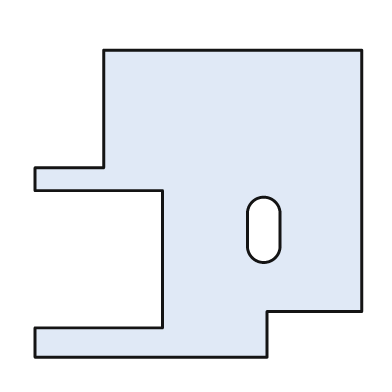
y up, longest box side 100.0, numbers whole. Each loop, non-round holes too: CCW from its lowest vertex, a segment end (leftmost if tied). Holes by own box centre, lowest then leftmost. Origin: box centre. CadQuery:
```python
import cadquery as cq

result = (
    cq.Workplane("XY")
    .moveTo(-50.0, -47.0)
    .lineTo(21.0, -47.0)
    .lineTo(21.0, -33.0)
    .lineTo(50.0, -33.0)
    .lineTo(50.0, 47.0)
    .lineTo(-29.0, 47.0)
    .lineTo(-29.0, 11.0)
    .lineTo(-50.0, 11.0)
    .lineTo(-50.0, 4.0)
    .lineTo(-11.0, 4.0)
    .lineTo(-11.0, -38.0)
    .lineTo(-50.0, -38.0)
    .close()
    .moveTo(15.0, -13.0)
    .threePointArc((20.0, -18.0), (25.0, -13.0))
    .lineTo(25.0, -3.0)
    .threePointArc((20.0, 2.0), (15.0, -3.0))
    .close()
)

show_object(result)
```